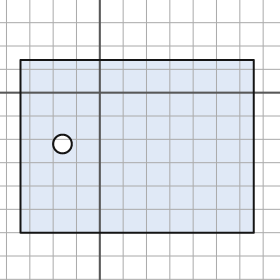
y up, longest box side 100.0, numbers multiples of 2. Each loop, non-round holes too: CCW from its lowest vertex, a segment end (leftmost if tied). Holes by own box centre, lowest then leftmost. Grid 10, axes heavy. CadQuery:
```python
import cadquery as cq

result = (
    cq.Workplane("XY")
    .moveTo(-34.0, -60.0)
    .lineTo(66.0, -60.0)
    .lineTo(66.0, 14.0)
    .lineTo(-34.0, 14.0)
    .close()
    .moveTo(-16.0, -22.0)
    .circle(4.0)
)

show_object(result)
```